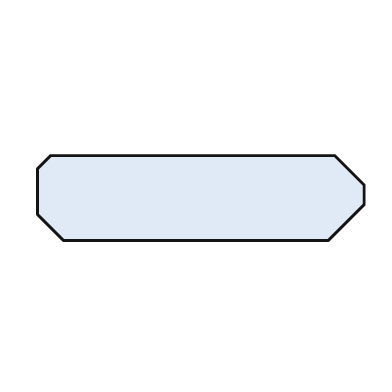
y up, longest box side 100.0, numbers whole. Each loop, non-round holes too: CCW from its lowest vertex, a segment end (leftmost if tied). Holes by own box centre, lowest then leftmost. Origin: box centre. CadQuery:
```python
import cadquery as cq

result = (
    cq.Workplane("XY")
    .moveTo(-42.0, -13.0)
    .lineTo(39.0, -13.0)
    .lineTo(50.0, -2.0)
    .lineTo(50.0, 4.0)
    .lineTo(41.0, 13.0)
    .lineTo(-46.0, 13.0)
    .lineTo(-50.0, 9.0)
    .lineTo(-50.0, -5.0)
    .close()
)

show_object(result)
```